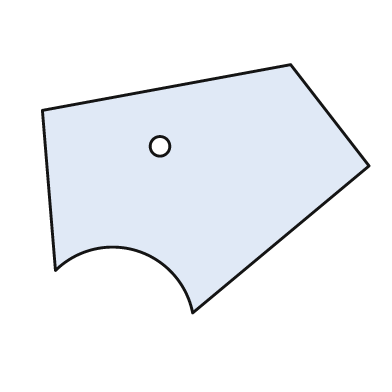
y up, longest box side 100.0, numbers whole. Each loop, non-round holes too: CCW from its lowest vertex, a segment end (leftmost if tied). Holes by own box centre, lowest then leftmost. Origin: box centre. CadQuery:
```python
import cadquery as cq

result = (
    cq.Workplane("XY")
    .moveTo(-4.0, -38.0)
    .lineTo(50.0, 7.0)
    .lineTo(26.0, 38.0)
    .lineTo(-50.0, 24.0)
    .lineTo(-46.0, -25.0)
    .threePointArc((-21.0, -19.0), (-4.0, -38.0))
    .close()
    .moveTo(-14.0, 13.0)
    .circle(3.0)
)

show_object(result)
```